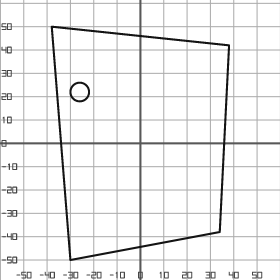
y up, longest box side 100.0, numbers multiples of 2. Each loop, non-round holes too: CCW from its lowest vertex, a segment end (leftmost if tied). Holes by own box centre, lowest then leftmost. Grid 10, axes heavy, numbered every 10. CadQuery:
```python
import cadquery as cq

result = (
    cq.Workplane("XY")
    .moveTo(-30.0, -50.0)
    .lineTo(34.0, -38.0)
    .lineTo(38.0, 42.0)
    .lineTo(-38.0, 50.0)
    .close()
    .moveTo(-26.0, 22.0)
    .circle(4.0)
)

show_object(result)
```